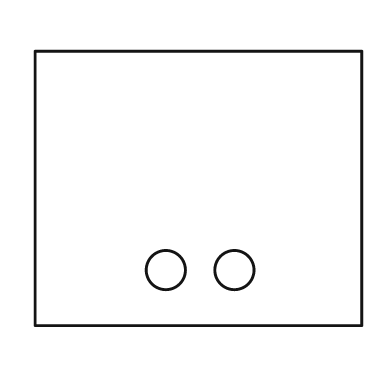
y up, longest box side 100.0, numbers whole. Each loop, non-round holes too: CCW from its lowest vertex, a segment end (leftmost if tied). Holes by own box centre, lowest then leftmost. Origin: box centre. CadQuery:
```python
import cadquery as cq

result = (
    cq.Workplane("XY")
    .moveTo(-50.0, -42.0)
    .lineTo(50.0, -42.0)
    .lineTo(50.0, 42.0)
    .lineTo(-50.0, 42.0)
    .close()
    .moveTo(-10.0, -25.0)
    .circle(6.0)
    .moveTo(11.0, -25.0)
    .circle(6.0)
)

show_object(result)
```